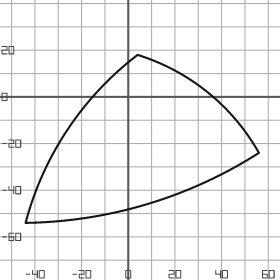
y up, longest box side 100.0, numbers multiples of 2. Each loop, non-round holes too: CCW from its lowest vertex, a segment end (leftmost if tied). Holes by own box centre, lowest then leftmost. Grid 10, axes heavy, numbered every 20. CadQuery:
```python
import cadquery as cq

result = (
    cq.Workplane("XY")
    .moveTo(-44.0, -54.0)
    .threePointArc((8.0, -46.0), (56.0, -24.0))
    .threePointArc((34.0, 2.0), (4.0, 18.0))
    .threePointArc((-26.0, -14.0), (-44.0, -54.0))
    .close()
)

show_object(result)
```